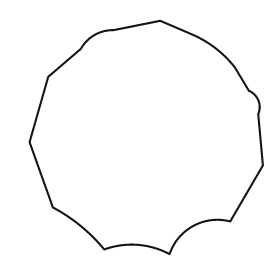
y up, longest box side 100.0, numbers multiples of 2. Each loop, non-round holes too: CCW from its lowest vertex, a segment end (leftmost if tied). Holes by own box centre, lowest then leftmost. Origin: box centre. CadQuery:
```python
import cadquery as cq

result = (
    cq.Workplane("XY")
    .moveTo(10.0, -50.0)
    .threePointArc((20.0, -38.0), (36.0, -36.0))
    .lineTo(50.0, -12.0)
    .lineTo(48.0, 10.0)
    .threePointArc((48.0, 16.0), (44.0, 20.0))
    .lineTo(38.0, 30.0)
    .threePointArc((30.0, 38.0), (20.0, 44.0))
    .lineTo(6.0, 50.0)
    .lineTo(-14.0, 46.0)
    .threePointArc((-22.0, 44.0), (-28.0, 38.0))
    .lineTo(-42.0, 26.0)
    .lineTo(-50.0, -2.0)
    .lineTo(-40.0, -30.0)
    .threePointArc((-28.0, -38.0), (-18.0, -48.0))
    .threePointArc((-4.0, -46.0), (10.0, -50.0))
    .close()
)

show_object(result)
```